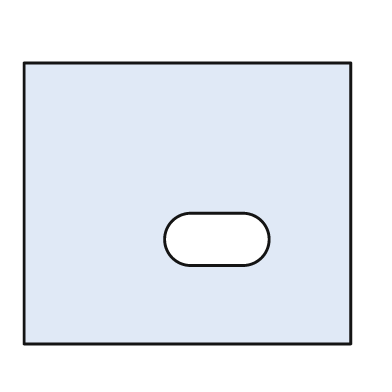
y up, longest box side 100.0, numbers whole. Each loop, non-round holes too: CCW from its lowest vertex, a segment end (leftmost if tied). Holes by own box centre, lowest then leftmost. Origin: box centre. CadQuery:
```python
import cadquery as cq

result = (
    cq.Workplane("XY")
    .moveTo(-50.0, -43.0)
    .lineTo(50.0, -43.0)
    .lineTo(50.0, 43.0)
    .lineTo(-50.0, 43.0)
    .close()
    .moveTo(1.0, -19.0)
    .lineTo(17.0, -19.0)
    .threePointArc((25.0, -11.0), (17.0, -3.0))
    .lineTo(1.0, -3.0)
    .threePointArc((-7.0, -11.0), (1.0, -19.0))
    .close()
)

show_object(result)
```